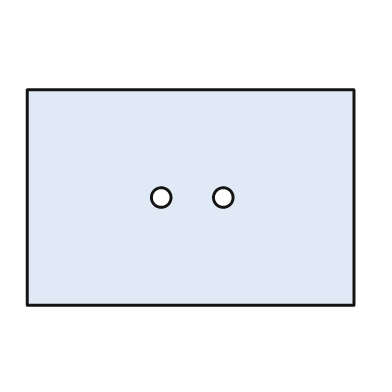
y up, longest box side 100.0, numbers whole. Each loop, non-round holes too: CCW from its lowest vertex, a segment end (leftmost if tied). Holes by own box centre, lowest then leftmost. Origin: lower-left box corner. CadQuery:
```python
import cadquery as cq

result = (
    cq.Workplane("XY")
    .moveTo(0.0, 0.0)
    .lineTo(100.0, 0.0)
    .lineTo(100.0, 66.0)
    .lineTo(0.0, 66.0)
    .close()
    .moveTo(41.0, 33.0)
    .circle(3.0)
    .moveTo(60.0, 33.0)
    .circle(3.0)
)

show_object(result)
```